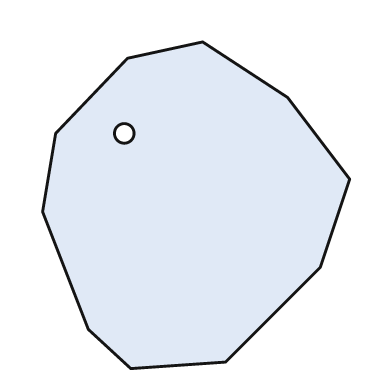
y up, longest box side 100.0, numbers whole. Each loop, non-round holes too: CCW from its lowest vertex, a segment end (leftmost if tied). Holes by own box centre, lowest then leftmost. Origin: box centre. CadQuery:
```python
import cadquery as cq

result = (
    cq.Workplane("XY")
    .moveTo(-20.0, -50.0)
    .lineTo(9.0, -48.0)
    .lineTo(38.0, -19.0)
    .lineTo(47.0, 8.0)
    .lineTo(28.0, 33.0)
    .lineTo(2.0, 50.0)
    .lineTo(-21.0, 45.0)
    .lineTo(-43.0, 22.0)
    .lineTo(-47.0, -2.0)
    .lineTo(-33.0, -38.0)
    .close()
    .moveTo(-22.0, 22.0)
    .circle(3.0)
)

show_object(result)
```